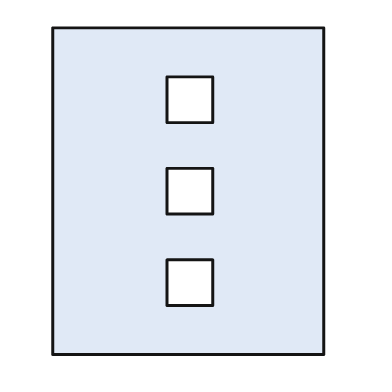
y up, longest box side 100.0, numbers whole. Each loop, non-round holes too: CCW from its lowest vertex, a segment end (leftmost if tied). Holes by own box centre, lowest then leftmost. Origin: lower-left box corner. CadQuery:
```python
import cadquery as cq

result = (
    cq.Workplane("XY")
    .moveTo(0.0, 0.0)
    .lineTo(83.0, 0.0)
    .lineTo(83.0, 100.0)
    .lineTo(0.0, 100.0)
    .close()
    .moveTo(35.0, 15.0)
    .lineTo(49.0, 15.0)
    .lineTo(49.0, 29.0)
    .lineTo(35.0, 29.0)
    .close()
    .moveTo(35.0, 43.0)
    .lineTo(49.0, 43.0)
    .lineTo(49.0, 57.0)
    .lineTo(35.0, 57.0)
    .close()
    .moveTo(35.0, 71.0)
    .lineTo(49.0, 71.0)
    .lineTo(49.0, 85.0)
    .lineTo(35.0, 85.0)
    .close()
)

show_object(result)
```